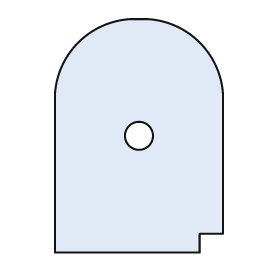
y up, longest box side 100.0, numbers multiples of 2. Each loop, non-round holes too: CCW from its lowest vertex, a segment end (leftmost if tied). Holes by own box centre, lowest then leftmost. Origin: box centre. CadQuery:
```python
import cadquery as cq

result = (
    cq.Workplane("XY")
    .moveTo(-36.0, -50.0)
    .lineTo(26.0, -50.0)
    .lineTo(26.0, -42.0)
    .lineTo(36.0, -42.0)
    .lineTo(36.0, 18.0)
    .threePointArc((26.0, 40.0), (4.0, 50.0))
    .lineTo(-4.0, 50.0)
    .threePointArc((-26.0, 40.0), (-36.0, 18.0))
    .close()
    .moveTo(0.0, 0.0)
    .circle(6.0)
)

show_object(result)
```